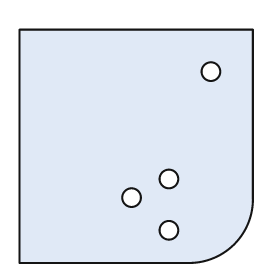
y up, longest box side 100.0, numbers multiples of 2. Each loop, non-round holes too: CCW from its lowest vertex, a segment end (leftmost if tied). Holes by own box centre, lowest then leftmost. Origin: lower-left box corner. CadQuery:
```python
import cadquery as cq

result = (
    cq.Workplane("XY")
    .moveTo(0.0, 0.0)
    .lineTo(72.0, 0.0)
    .threePointArc((92.0, 8.0), (100.0, 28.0))
    .lineTo(100.0, 100.0)
    .lineTo(0.0, 100.0)
    .close()
    .moveTo(64.0, 14.0)
    .circle(4.0)
    .moveTo(48.0, 28.0)
    .circle(4.0)
    .moveTo(64.0, 36.0)
    .circle(4.0)
    .moveTo(82.0, 82.0)
    .circle(4.0)
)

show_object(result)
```